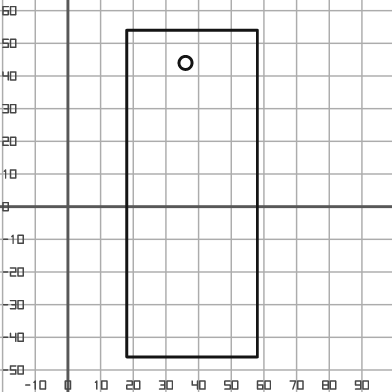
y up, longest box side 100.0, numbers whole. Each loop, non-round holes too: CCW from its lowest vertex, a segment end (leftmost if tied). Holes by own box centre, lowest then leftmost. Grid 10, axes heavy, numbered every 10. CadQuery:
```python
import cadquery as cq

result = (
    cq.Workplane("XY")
    .moveTo(18.0, -46.0)
    .lineTo(58.0, -46.0)
    .lineTo(58.0, 54.0)
    .lineTo(18.0, 54.0)
    .close()
    .moveTo(36.0, 44.0)
    .circle(2.0)
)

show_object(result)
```